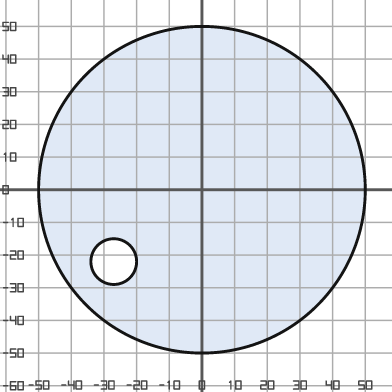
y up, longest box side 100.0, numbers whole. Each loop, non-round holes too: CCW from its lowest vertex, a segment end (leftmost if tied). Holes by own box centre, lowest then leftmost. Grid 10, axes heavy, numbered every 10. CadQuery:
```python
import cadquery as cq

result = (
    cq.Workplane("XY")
    .moveTo(0.0, 0.0)
    .circle(50.0)
    .moveTo(-27.0, -22.0)
    .circle(7.0)
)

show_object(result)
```